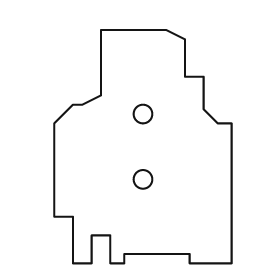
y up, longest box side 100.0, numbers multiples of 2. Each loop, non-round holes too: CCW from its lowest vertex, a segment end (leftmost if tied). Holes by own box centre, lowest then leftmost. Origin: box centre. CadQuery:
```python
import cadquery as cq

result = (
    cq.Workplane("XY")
    .moveTo(-30.0, -50.0)
    .lineTo(-22.0, -50.0)
    .lineTo(-22.0, -38.0)
    .lineTo(-14.0, -38.0)
    .lineTo(-14.0, -50.0)
    .lineTo(-8.0, -50.0)
    .lineTo(-8.0, -46.0)
    .lineTo(20.0, -46.0)
    .lineTo(20.0, -50.0)
    .lineTo(38.0, -50.0)
    .lineTo(38.0, 10.0)
    .lineTo(32.0, 10.0)
    .lineTo(26.0, 16.0)
    .lineTo(26.0, 30.0)
    .lineTo(18.0, 30.0)
    .lineTo(18.0, 46.0)
    .lineTo(10.0, 50.0)
    .lineTo(-18.0, 50.0)
    .lineTo(-18.0, 22.0)
    .lineTo(-26.0, 18.0)
    .lineTo(-30.0, 18.0)
    .lineTo(-38.0, 10.0)
    .lineTo(-38.0, -30.0)
    .lineTo(-30.0, -30.0)
    .close()
    .moveTo(0.0, -14.0)
    .circle(4.0)
    .moveTo(0.0, 14.0)
    .circle(4.0)
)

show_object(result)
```